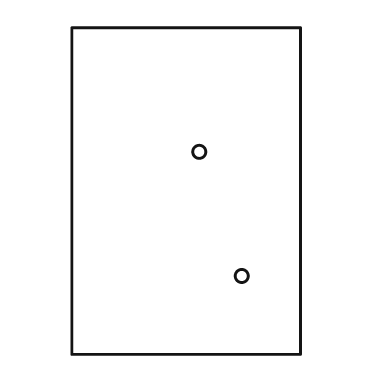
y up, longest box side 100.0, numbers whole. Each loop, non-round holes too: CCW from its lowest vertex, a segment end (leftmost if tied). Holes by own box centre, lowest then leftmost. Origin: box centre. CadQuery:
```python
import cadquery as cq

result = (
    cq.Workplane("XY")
    .moveTo(-35.0, -50.0)
    .lineTo(35.0, -50.0)
    .lineTo(35.0, 50.0)
    .lineTo(-35.0, 50.0)
    .close()
    .moveTo(17.0, -26.0)
    .circle(2.0)
    .moveTo(4.0, 12.0)
    .circle(2.0)
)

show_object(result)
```